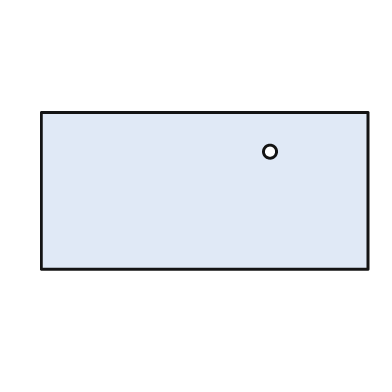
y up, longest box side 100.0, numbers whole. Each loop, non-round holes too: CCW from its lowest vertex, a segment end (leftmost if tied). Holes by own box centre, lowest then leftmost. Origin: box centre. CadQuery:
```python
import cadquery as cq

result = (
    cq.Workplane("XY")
    .moveTo(-50.0, -24.0)
    .lineTo(50.0, -24.0)
    .lineTo(50.0, 24.0)
    .lineTo(-50.0, 24.0)
    .close()
    .moveTo(20.0, 12.0)
    .circle(2.0)
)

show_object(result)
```